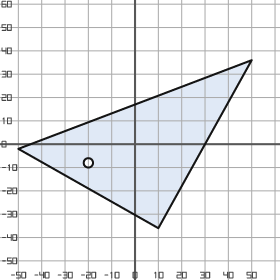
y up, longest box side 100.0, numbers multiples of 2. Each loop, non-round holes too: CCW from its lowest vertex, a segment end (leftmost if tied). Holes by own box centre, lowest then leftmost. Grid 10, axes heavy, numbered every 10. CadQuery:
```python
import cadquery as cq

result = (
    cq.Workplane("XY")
    .moveTo(10.0, -36.0)
    .lineTo(50.0, 36.0)
    .lineTo(-50.0, -2.0)
    .close()
    .moveTo(-20.0, -8.0)
    .circle(2.0)
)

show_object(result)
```